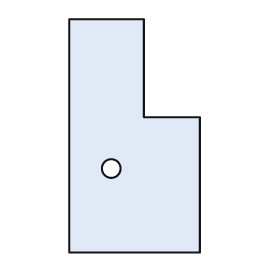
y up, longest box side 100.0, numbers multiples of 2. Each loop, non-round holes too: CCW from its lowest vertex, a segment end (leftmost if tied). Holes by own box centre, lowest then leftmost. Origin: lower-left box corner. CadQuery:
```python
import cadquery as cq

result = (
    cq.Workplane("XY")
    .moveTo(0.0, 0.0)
    .lineTo(56.0, 0.0)
    .lineTo(56.0, 58.0)
    .lineTo(32.0, 58.0)
    .lineTo(32.0, 100.0)
    .lineTo(0.0, 100.0)
    .close()
    .moveTo(18.0, 36.0)
    .circle(4.0)
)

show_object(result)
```